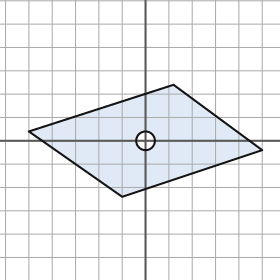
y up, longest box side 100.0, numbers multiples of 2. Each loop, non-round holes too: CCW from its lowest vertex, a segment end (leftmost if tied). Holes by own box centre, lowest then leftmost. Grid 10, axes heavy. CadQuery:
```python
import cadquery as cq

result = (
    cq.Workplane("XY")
    .moveTo(-10.0, -24.0)
    .lineTo(50.0, -4.0)
    .lineTo(12.0, 24.0)
    .lineTo(-50.0, 4.0)
    .close()
    .moveTo(0.0, 0.0)
    .circle(4.0)
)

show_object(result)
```